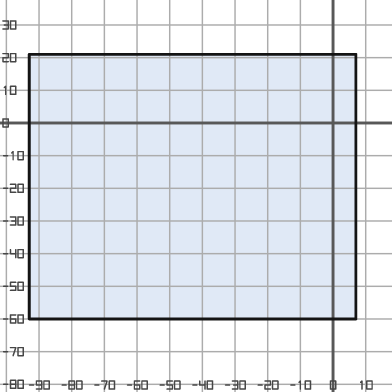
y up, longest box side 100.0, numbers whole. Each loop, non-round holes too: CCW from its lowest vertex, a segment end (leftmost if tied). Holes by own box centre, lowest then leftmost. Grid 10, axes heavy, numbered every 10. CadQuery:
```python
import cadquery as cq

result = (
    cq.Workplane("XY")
    .moveTo(-93.0, -60.0)
    .lineTo(7.0, -60.0)
    .lineTo(7.0, 21.0)
    .lineTo(-93.0, 21.0)
    .close()
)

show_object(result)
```